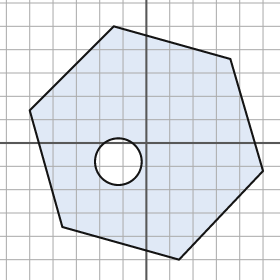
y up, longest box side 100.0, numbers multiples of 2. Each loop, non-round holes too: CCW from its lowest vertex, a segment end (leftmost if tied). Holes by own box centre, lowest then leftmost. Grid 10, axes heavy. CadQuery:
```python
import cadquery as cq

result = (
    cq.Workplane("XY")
    .moveTo(14.0, -50.0)
    .lineTo(50.0, -12.0)
    .lineTo(36.0, 36.0)
    .lineTo(-14.0, 50.0)
    .lineTo(-50.0, 14.0)
    .lineTo(-36.0, -36.0)
    .close()
    .moveTo(-12.0, -8.0)
    .circle(10.0)
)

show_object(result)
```